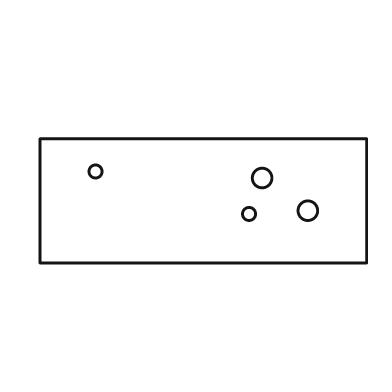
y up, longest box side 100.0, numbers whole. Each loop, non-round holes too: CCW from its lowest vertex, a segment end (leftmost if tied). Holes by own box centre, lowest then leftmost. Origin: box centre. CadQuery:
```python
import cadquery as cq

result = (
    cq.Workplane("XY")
    .moveTo(-50.0, -19.0)
    .lineTo(50.0, -19.0)
    .lineTo(50.0, 19.0)
    .lineTo(-50.0, 19.0)
    .close()
    .moveTo(14.0, -4.0)
    .circle(2.0)
    .moveTo(32.0, -3.0)
    .circle(3.0)
    .moveTo(18.0, 7.0)
    .circle(3.0)
    .moveTo(-33.0, 9.0)
    .circle(2.0)
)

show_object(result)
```